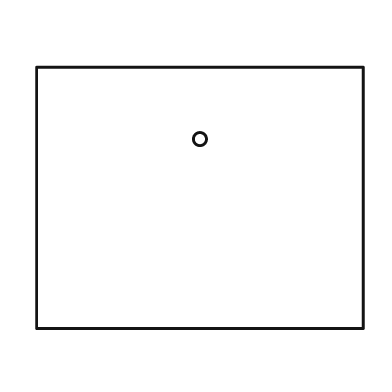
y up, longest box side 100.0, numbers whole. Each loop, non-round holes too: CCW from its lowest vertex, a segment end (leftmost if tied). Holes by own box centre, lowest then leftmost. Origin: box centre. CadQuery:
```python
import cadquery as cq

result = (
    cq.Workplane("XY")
    .moveTo(-50.0, -40.0)
    .lineTo(50.0, -40.0)
    .lineTo(50.0, 40.0)
    .lineTo(-50.0, 40.0)
    .close()
    .moveTo(0.0, 18.0)
    .circle(2.0)
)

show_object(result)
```